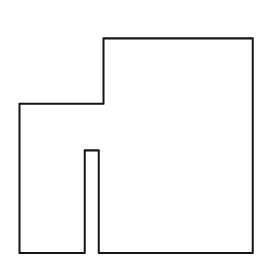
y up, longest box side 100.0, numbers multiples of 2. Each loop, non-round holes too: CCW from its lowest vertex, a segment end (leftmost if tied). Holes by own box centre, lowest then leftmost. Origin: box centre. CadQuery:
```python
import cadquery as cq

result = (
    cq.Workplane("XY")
    .moveTo(-50.0, -46.0)
    .lineTo(-22.0, -46.0)
    .lineTo(-22.0, -2.0)
    .lineTo(-16.0, -2.0)
    .lineTo(-16.0, -46.0)
    .lineTo(50.0, -46.0)
    .lineTo(50.0, 46.0)
    .lineTo(-14.0, 46.0)
    .lineTo(-14.0, 18.0)
    .lineTo(-50.0, 18.0)
    .close()
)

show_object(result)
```